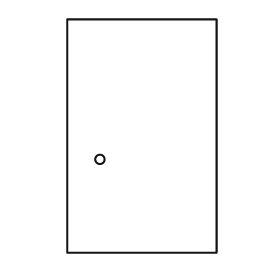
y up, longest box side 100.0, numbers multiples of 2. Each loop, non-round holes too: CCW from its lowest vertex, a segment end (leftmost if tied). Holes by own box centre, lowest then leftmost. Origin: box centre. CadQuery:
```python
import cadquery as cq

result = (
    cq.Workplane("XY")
    .moveTo(-32.0, -50.0)
    .lineTo(32.0, -50.0)
    .lineTo(32.0, 50.0)
    .lineTo(-32.0, 50.0)
    .close()
    .moveTo(-18.0, -10.0)
    .circle(2.0)
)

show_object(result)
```